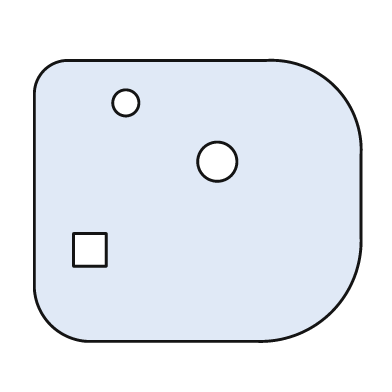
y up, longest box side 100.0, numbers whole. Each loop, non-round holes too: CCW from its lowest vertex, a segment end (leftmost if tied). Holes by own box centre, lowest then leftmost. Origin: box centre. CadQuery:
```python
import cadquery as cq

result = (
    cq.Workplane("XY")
    .moveTo(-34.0, -43.0)
    .lineTo(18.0, -43.0)
    .threePointArc((41.0, -34.0), (50.0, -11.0))
    .lineTo(50.0, 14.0)
    .threePointArc((42.0, 35.0), (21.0, 43.0))
    .lineTo(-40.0, 43.0)
    .threePointArc((-47.0, 40.0), (-50.0, 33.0))
    .lineTo(-50.0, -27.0)
    .threePointArc((-45.0, -38.0), (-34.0, -43.0))
    .close()
    .moveTo(-38.0, -20.0)
    .lineTo(-28.0, -20.0)
    .lineTo(-28.0, -10.0)
    .lineTo(-38.0, -10.0)
    .close()
    .moveTo(6.0, 12.0)
    .circle(6.0)
    .moveTo(-22.0, 30.0)
    .circle(4.0)
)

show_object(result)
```